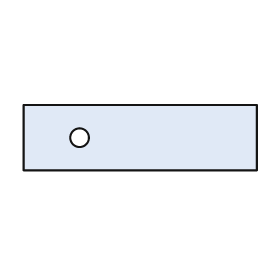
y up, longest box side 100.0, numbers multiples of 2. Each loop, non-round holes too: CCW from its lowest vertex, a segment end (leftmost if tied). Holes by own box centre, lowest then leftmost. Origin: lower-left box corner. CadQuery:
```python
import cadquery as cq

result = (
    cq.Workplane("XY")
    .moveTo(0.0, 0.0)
    .lineTo(100.0, 0.0)
    .lineTo(100.0, 28.0)
    .lineTo(0.0, 28.0)
    .close()
    .moveTo(24.0, 14.0)
    .circle(4.0)
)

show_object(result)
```